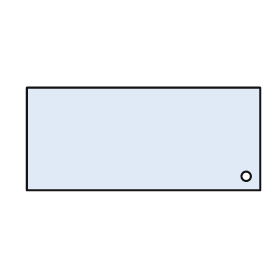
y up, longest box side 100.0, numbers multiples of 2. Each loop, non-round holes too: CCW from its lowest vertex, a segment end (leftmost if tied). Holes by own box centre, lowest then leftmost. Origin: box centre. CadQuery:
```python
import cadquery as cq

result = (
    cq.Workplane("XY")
    .moveTo(-50.0, -22.0)
    .lineTo(50.0, -22.0)
    .lineTo(50.0, 22.0)
    .lineTo(-50.0, 22.0)
    .close()
    .moveTo(44.0, -16.0)
    .circle(2.0)
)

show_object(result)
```